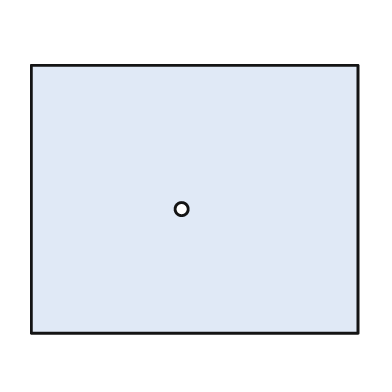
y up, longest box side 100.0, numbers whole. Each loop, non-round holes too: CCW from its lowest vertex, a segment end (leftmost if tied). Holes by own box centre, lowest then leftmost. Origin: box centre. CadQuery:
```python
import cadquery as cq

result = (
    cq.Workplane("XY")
    .moveTo(-50.0, -41.0)
    .lineTo(50.0, -41.0)
    .lineTo(50.0, 41.0)
    .lineTo(-50.0, 41.0)
    .close()
    .moveTo(-4.0, -3.0)
    .circle(2.0)
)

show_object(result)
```